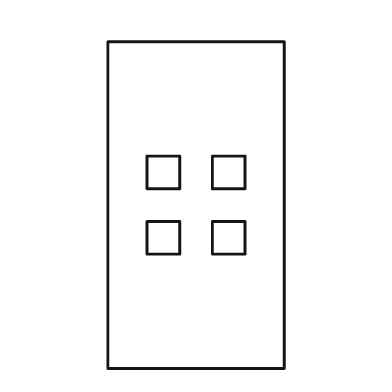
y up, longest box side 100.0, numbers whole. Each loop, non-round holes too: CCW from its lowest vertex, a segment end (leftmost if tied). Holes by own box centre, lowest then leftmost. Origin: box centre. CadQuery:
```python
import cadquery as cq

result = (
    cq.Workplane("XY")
    .moveTo(-27.0, -50.0)
    .lineTo(27.0, -50.0)
    .lineTo(27.0, 50.0)
    .lineTo(-27.0, 50.0)
    .close()
    .moveTo(-15.0, -15.0)
    .lineTo(-5.0, -15.0)
    .lineTo(-5.0, -5.0)
    .lineTo(-15.0, -5.0)
    .close()
    .moveTo(5.0, -15.0)
    .lineTo(15.0, -15.0)
    .lineTo(15.0, -5.0)
    .lineTo(5.0, -5.0)
    .close()
    .moveTo(-15.0, 5.0)
    .lineTo(-5.0, 5.0)
    .lineTo(-5.0, 15.0)
    .lineTo(-15.0, 15.0)
    .close()
    .moveTo(5.0, 5.0)
    .lineTo(15.0, 5.0)
    .lineTo(15.0, 15.0)
    .lineTo(5.0, 15.0)
    .close()
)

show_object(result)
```